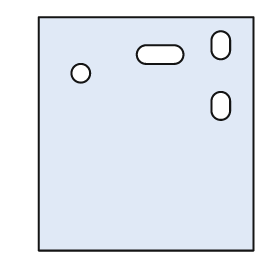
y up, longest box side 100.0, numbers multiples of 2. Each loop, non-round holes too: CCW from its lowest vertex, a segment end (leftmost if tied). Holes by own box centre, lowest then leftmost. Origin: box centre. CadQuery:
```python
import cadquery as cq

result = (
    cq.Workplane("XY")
    .moveTo(-46.0, -50.0)
    .lineTo(46.0, -50.0)
    .lineTo(46.0, 50.0)
    .lineTo(-46.0, 50.0)
    .close()
    .moveTo(28.0, 10.0)
    .threePointArc((32.0, 6.0), (36.0, 10.0))
    .lineTo(36.0, 14.0)
    .threePointArc((32.0, 18.0), (28.0, 14.0))
    .close()
    .moveTo(-28.0, 26.0)
    .circle(4.0)
    .moveTo(0.0, 30.0)
    .lineTo(12.0, 30.0)
    .threePointArc((16.0, 34.0), (12.0, 38.0))
    .lineTo(0.0, 38.0)
    .threePointArc((-4.0, 34.0), (0.0, 30.0))
    .close()
    .moveTo(28.0, 36.0)
    .threePointArc((32.0, 32.0), (36.0, 36.0))
    .lineTo(36.0, 40.0)
    .threePointArc((32.0, 44.0), (28.0, 40.0))
    .close()
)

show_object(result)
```